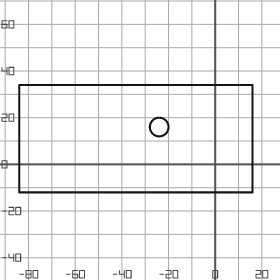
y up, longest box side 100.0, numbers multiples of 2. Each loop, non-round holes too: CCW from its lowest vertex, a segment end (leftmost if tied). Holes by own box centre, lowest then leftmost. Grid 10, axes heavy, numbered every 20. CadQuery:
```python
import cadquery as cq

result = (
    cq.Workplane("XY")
    .moveTo(-84.0, -12.0)
    .lineTo(16.0, -12.0)
    .lineTo(16.0, 34.0)
    .lineTo(-84.0, 34.0)
    .close()
    .moveTo(-24.0, 16.0)
    .circle(4.0)
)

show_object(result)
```